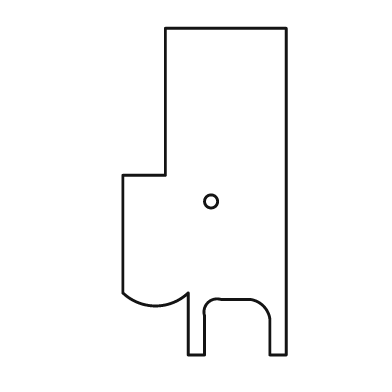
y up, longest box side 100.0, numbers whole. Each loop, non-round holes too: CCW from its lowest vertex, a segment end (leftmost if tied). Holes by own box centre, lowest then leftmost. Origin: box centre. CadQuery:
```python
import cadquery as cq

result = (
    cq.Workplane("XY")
    .moveTo(-5.0, -50.0)
    .lineTo(0.0, -50.0)
    .lineTo(0.0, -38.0)
    .threePointArc((1.0, -34.0), (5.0, -33.0))
    .lineTo(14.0, -33.0)
    .threePointArc((18.0, -35.0), (20.0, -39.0))
    .lineTo(20.0, -50.0)
    .lineTo(25.0, -50.0)
    .lineTo(25.0, 50.0)
    .lineTo(-12.0, 50.0)
    .lineTo(-12.0, 5.0)
    .lineTo(-25.0, 5.0)
    .lineTo(-25.0, -31.0)
    .threePointArc((-15.0, -35.0), (-5.0, -31.0))
    .close()
    .moveTo(2.0, -3.0)
    .circle(2.0)
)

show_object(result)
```